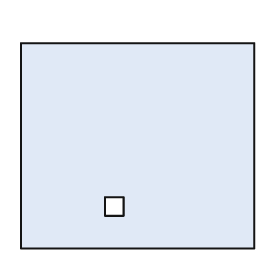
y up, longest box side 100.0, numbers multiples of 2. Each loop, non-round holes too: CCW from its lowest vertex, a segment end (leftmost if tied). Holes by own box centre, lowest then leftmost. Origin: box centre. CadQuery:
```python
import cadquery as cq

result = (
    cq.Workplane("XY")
    .moveTo(-50.0, -44.0)
    .lineTo(50.0, -44.0)
    .lineTo(50.0, 44.0)
    .lineTo(-50.0, 44.0)
    .close()
    .moveTo(-14.0, -30.0)
    .lineTo(-6.0, -30.0)
    .lineTo(-6.0, -22.0)
    .lineTo(-14.0, -22.0)
    .close()
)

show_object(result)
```